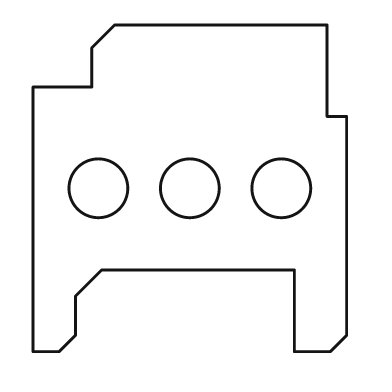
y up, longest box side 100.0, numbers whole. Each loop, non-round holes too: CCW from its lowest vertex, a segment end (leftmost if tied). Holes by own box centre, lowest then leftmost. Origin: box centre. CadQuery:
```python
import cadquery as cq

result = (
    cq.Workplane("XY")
    .moveTo(-48.0, -50.0)
    .lineTo(-40.0, -50.0)
    .lineTo(-35.0, -45.0)
    .lineTo(-35.0, -33.0)
    .lineTo(-27.0, -25.0)
    .lineTo(32.0, -25.0)
    .lineTo(32.0, -50.0)
    .lineTo(43.0, -50.0)
    .lineTo(48.0, -45.0)
    .lineTo(48.0, 22.0)
    .lineTo(42.0, 22.0)
    .lineTo(42.0, 50.0)
    .lineTo(-23.0, 50.0)
    .lineTo(-30.0, 43.0)
    .lineTo(-30.0, 31.0)
    .lineTo(-48.0, 31.0)
    .close()
    .moveTo(-28.0, 0.0)
    .circle(9.0)
    .moveTo(0.0, 0.0)
    .circle(9.0)
    .moveTo(28.0, 0.0)
    .circle(9.0)
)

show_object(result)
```